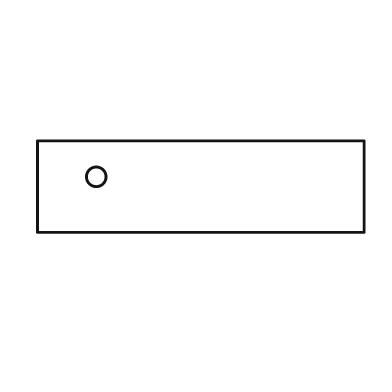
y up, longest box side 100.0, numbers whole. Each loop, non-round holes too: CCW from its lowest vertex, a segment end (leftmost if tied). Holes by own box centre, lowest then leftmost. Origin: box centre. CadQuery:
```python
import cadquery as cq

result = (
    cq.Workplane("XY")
    .moveTo(-50.0, -14.0)
    .lineTo(50.0, -14.0)
    .lineTo(50.0, 14.0)
    .lineTo(-50.0, 14.0)
    .close()
    .moveTo(-32.0, 3.0)
    .circle(3.0)
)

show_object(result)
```